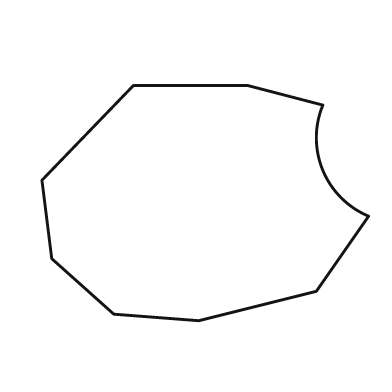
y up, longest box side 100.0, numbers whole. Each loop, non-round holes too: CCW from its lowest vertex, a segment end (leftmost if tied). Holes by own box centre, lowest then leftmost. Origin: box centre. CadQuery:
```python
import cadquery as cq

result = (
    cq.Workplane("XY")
    .moveTo(-2.0, -36.0)
    .lineTo(34.0, -27.0)
    .lineTo(50.0, -4.0)
    .threePointArc((36.0, 10.0), (36.0, 30.0))
    .lineTo(13.0, 36.0)
    .lineTo(-22.0, 36.0)
    .lineTo(-50.0, 7.0)
    .lineTo(-47.0, -17.0)
    .lineTo(-28.0, -34.0)
    .close()
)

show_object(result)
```